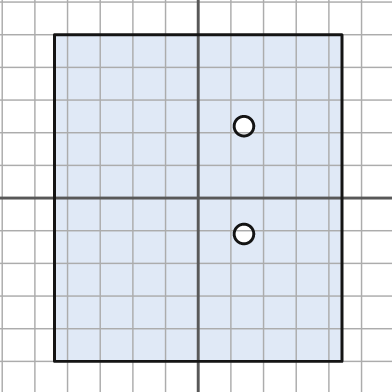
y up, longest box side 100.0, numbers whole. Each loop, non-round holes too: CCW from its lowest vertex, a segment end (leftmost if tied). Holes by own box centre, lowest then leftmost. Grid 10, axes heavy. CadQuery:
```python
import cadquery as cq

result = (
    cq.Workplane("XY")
    .moveTo(-44.0, -50.0)
    .lineTo(44.0, -50.0)
    .lineTo(44.0, 50.0)
    .lineTo(-44.0, 50.0)
    .close()
    .moveTo(14.0, -11.0)
    .circle(3.0)
    .moveTo(14.0, 22.0)
    .circle(3.0)
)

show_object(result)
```